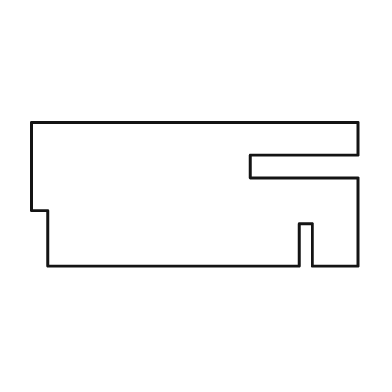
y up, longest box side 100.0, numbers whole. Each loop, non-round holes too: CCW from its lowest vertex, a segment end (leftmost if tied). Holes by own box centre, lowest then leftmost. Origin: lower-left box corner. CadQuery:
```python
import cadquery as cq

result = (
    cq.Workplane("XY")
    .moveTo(5.0, 0.0)
    .lineTo(82.0, 0.0)
    .lineTo(82.0, 13.0)
    .lineTo(86.0, 13.0)
    .lineTo(86.0, 0.0)
    .lineTo(100.0, 0.0)
    .lineTo(100.0, 27.0)
    .lineTo(67.0, 27.0)
    .lineTo(67.0, 34.0)
    .lineTo(100.0, 34.0)
    .lineTo(100.0, 44.0)
    .lineTo(0.0, 44.0)
    .lineTo(0.0, 17.0)
    .lineTo(5.0, 17.0)
    .close()
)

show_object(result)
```